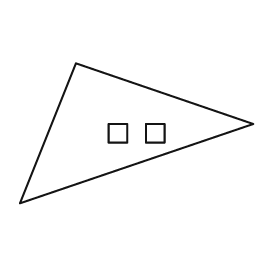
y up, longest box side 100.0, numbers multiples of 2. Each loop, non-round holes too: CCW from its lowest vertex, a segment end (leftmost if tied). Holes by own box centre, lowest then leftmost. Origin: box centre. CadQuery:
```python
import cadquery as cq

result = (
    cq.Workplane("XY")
    .moveTo(-50.0, -30.0)
    .lineTo(50.0, 4.0)
    .lineTo(-26.0, 30.0)
    .close()
    .moveTo(-12.0, -4.0)
    .lineTo(-4.0, -4.0)
    .lineTo(-4.0, 4.0)
    .lineTo(-12.0, 4.0)
    .close()
    .moveTo(4.0, -4.0)
    .lineTo(12.0, -4.0)
    .lineTo(12.0, 4.0)
    .lineTo(4.0, 4.0)
    .close()
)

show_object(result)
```